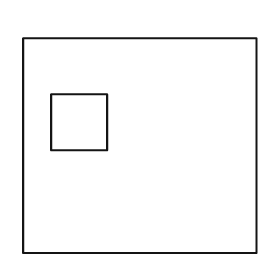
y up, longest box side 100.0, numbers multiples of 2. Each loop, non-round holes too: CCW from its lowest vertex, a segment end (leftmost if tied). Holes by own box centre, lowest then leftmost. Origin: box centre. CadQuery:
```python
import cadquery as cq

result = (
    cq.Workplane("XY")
    .moveTo(-50.0, -46.0)
    .lineTo(50.0, -46.0)
    .lineTo(50.0, 46.0)
    .lineTo(-50.0, 46.0)
    .close()
    .moveTo(-38.0, -2.0)
    .lineTo(-14.0, -2.0)
    .lineTo(-14.0, 22.0)
    .lineTo(-38.0, 22.0)
    .close()
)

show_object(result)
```